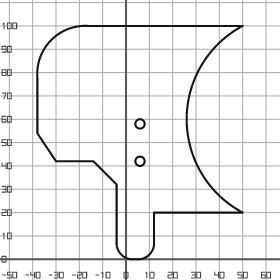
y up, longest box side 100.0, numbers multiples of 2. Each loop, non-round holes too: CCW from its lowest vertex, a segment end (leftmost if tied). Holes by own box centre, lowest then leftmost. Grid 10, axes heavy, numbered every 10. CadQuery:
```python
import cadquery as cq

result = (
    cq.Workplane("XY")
    .moveTo(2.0, 0.0)
    .lineTo(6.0, 0.0)
    .threePointArc((10.0, 2.0), (12.0, 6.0))
    .lineTo(12.0, 20.0)
    .lineTo(50.0, 20.0)
    .threePointArc((26.0, 60.0), (50.0, 100.0))
    .lineTo(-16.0, 100.0)
    .threePointArc((-32.0, 94.0), (-38.0, 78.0))
    .lineTo(-38.0, 54.0)
    .lineTo(-30.0, 42.0)
    .lineTo(-14.0, 42.0)
    .lineTo(-4.0, 32.0)
    .lineTo(-4.0, 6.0)
    .threePointArc((-2.0, 2.0), (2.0, 0.0))
    .close()
    .moveTo(6.0, 42.0)
    .circle(2.0)
    .moveTo(6.0, 58.0)
    .circle(2.0)
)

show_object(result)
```